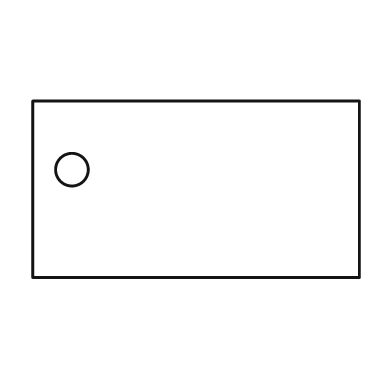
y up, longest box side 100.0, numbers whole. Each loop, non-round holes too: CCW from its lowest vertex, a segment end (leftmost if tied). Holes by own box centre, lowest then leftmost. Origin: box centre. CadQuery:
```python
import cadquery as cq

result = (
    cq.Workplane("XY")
    .moveTo(-50.0, -27.0)
    .lineTo(50.0, -27.0)
    .lineTo(50.0, 27.0)
    .lineTo(-50.0, 27.0)
    .close()
    .moveTo(-38.0, 6.0)
    .circle(5.0)
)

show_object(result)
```